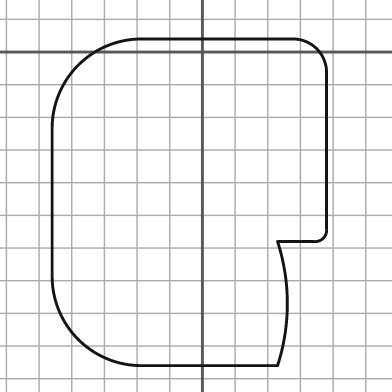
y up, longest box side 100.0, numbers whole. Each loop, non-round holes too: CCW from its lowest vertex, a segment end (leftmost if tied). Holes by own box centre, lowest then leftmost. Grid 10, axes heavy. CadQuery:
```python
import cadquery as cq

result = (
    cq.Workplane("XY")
    .moveTo(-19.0, -96.0)
    .lineTo(23.0, -96.0)
    .threePointArc((26.0, -77.0), (23.0, -58.0))
    .lineTo(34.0, -58.0)
    .threePointArc((37.0, -57.0), (38.0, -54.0))
    .lineTo(38.0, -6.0)
    .threePointArc((35.0, 1.0), (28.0, 4.0))
    .lineTo(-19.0, 4.0)
    .threePointArc((-38.0, -4.0), (-46.0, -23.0))
    .lineTo(-46.0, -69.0)
    .threePointArc((-38.0, -88.0), (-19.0, -96.0))
    .close()
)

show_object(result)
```